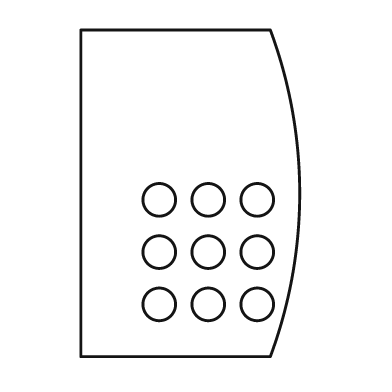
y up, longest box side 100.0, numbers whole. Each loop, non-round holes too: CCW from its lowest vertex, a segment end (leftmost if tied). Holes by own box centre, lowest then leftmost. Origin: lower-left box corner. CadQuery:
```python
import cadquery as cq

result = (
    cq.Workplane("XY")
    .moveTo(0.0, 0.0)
    .lineTo(58.0, 0.0)
    .threePointArc((67.0, 50.0), (58.0, 100.0))
    .lineTo(0.0, 100.0)
    .close()
    .moveTo(24.0, 16.0)
    .circle(5.0)
    .moveTo(39.0, 16.0)
    .circle(5.0)
    .moveTo(54.0, 16.0)
    .circle(5.0)
    .moveTo(24.0, 32.0)
    .circle(5.0)
    .moveTo(39.0, 32.0)
    .circle(5.0)
    .moveTo(54.0, 32.0)
    .circle(5.0)
    .moveTo(24.0, 48.0)
    .circle(5.0)
    .moveTo(39.0, 48.0)
    .circle(5.0)
    .moveTo(54.0, 48.0)
    .circle(5.0)
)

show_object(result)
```